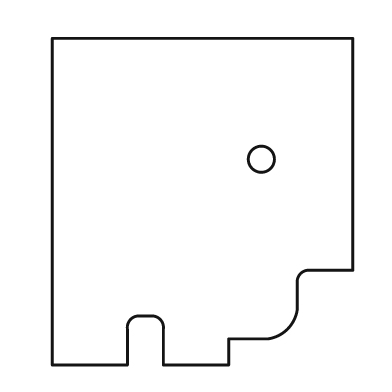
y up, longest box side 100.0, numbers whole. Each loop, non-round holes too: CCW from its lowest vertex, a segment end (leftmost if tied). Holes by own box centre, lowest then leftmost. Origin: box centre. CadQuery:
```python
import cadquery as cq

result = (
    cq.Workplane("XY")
    .moveTo(-46.0, -50.0)
    .lineTo(-23.0, -50.0)
    .lineTo(-23.0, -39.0)
    .threePointArc((-22.0, -36.0), (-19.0, -35.0))
    .lineTo(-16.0, -35.0)
    .threePointArc((-13.0, -36.0), (-12.0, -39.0))
    .lineTo(-12.0, -50.0)
    .lineTo(8.0, -50.0)
    .lineTo(8.0, -42.0)
    .lineTo(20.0, -42.0)
    .threePointArc((26.0, -39.0), (29.0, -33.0))
    .lineTo(29.0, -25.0)
    .threePointArc((30.0, -22.0), (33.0, -21.0))
    .lineTo(46.0, -21.0)
    .lineTo(46.0, 50.0)
    .lineTo(-46.0, 50.0)
    .close()
    .moveTo(18.0, 13.0)
    .circle(4.0)
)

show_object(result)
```